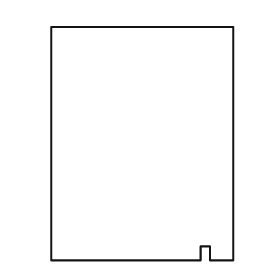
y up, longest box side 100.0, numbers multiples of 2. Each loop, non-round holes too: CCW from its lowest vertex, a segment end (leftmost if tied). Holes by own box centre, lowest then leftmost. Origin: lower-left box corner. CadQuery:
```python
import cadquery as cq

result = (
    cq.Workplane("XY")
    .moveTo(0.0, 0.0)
    .lineTo(64.0, 0.0)
    .lineTo(64.0, 6.0)
    .lineTo(68.0, 6.0)
    .lineTo(68.0, 0.0)
    .lineTo(78.0, 0.0)
    .lineTo(78.0, 100.0)
    .lineTo(0.0, 100.0)
    .close()
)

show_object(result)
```